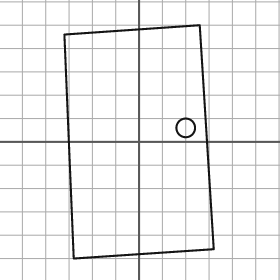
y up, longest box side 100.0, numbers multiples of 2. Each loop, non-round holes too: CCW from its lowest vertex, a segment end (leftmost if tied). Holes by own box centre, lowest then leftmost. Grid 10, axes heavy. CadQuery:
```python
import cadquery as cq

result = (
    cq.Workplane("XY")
    .moveTo(-28.0, -50.0)
    .lineTo(32.0, -46.0)
    .lineTo(26.0, 50.0)
    .lineTo(-32.0, 46.0)
    .close()
    .moveTo(20.0, 6.0)
    .circle(4.0)
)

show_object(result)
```